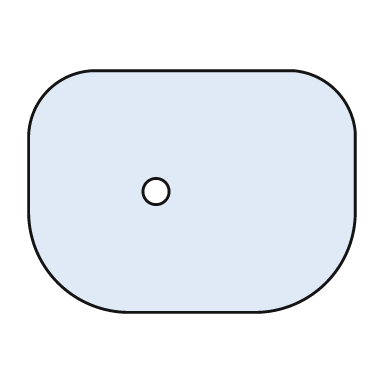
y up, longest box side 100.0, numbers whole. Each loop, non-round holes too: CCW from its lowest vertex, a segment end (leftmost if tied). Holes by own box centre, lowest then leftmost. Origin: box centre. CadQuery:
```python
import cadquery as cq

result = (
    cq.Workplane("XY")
    .moveTo(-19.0, -37.0)
    .lineTo(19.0, -37.0)
    .threePointArc((41.0, -28.0), (50.0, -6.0))
    .lineTo(50.0, 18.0)
    .threePointArc((44.0, 31.0), (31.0, 37.0))
    .lineTo(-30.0, 37.0)
    .threePointArc((-44.0, 31.0), (-50.0, 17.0))
    .lineTo(-50.0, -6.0)
    .threePointArc((-41.0, -28.0), (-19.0, -37.0))
    .close()
    .moveTo(-11.0, 0.0)
    .circle(4.0)
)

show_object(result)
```